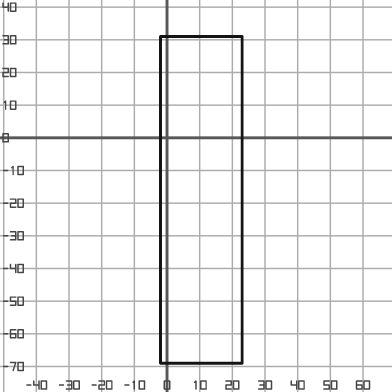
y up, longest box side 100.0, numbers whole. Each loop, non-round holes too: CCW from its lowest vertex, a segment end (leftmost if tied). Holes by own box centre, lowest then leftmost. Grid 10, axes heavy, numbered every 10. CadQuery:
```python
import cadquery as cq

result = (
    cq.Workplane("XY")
    .moveTo(-2.0, -69.0)
    .lineTo(23.0, -69.0)
    .lineTo(23.0, 31.0)
    .lineTo(-2.0, 31.0)
    .close()
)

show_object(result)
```